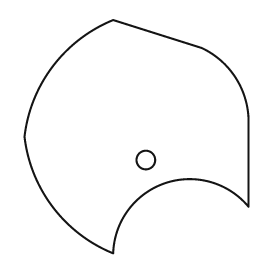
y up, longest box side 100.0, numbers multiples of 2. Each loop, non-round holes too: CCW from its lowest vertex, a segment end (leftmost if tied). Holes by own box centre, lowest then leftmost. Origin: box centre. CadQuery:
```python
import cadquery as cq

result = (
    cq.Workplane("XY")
    .moveTo(-10.0, -50.0)
    .threePointArc((12.0, -20.0), (48.0, -30.0))
    .lineTo(48.0, 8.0)
    .threePointArc((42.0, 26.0), (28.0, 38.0))
    .lineTo(-10.0, 50.0)
    .threePointArc((-36.0, 30.0), (-48.0, 0.0))
    .threePointArc((-36.0, -30.0), (-10.0, -50.0))
    .close()
    .moveTo(4.0, -10.0)
    .circle(4.0)
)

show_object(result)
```